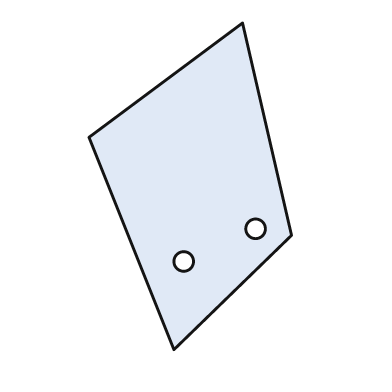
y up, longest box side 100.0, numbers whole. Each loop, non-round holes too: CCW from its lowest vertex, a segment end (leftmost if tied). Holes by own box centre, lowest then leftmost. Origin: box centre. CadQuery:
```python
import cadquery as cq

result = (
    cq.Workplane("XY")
    .moveTo(-5.0, -50.0)
    .lineTo(31.0, -15.0)
    .lineTo(16.0, 50.0)
    .lineTo(-31.0, 15.0)
    .close()
    .moveTo(-2.0, -23.0)
    .circle(3.0)
    .moveTo(20.0, -13.0)
    .circle(3.0)
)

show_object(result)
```